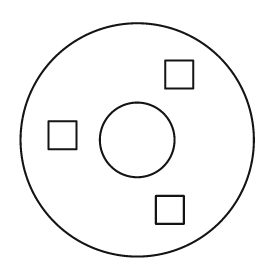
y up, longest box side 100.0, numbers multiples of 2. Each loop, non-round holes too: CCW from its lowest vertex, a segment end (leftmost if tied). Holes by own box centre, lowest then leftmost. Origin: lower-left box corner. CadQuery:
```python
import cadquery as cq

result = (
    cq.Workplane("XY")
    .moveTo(50.0, 50.0)
    .circle(50.0)
    .moveTo(58.0, 14.0)
    .lineTo(70.0, 14.0)
    .lineTo(70.0, 26.0)
    .lineTo(58.0, 26.0)
    .close()
    .moveTo(50.0, 50.0)
    .circle(16.0)
    .moveTo(12.0, 46.0)
    .lineTo(24.0, 46.0)
    .lineTo(24.0, 58.0)
    .lineTo(12.0, 58.0)
    .close()
    .moveTo(62.0, 72.0)
    .lineTo(74.0, 72.0)
    .lineTo(74.0, 84.0)
    .lineTo(62.0, 84.0)
    .close()
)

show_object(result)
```